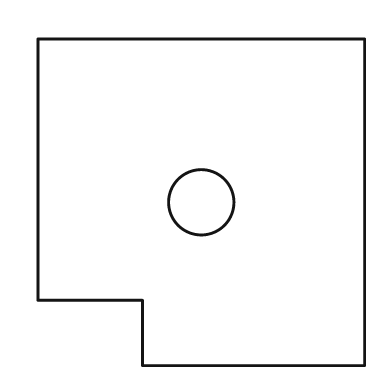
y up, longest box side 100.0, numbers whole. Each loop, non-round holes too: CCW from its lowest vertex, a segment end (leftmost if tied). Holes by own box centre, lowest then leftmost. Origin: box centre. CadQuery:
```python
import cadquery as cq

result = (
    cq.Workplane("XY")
    .moveTo(-18.0, -50.0)
    .lineTo(50.0, -50.0)
    .lineTo(50.0, 50.0)
    .lineTo(-50.0, 50.0)
    .lineTo(-50.0, -30.0)
    .lineTo(-18.0, -30.0)
    .close()
    .moveTo(0.0, 0.0)
    .circle(10.0)
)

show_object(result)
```